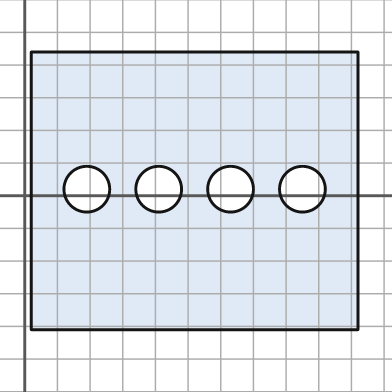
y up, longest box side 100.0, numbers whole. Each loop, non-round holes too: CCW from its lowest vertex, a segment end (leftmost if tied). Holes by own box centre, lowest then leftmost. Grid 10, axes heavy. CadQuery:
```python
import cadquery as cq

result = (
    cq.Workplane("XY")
    .moveTo(2.0, -41.0)
    .lineTo(102.0, -41.0)
    .lineTo(102.0, 44.0)
    .lineTo(2.0, 44.0)
    .close()
    .moveTo(19.0, 2.0)
    .circle(7.0)
    .moveTo(41.0, 2.0)
    .circle(7.0)
    .moveTo(63.0, 2.0)
    .circle(7.0)
    .moveTo(85.0, 2.0)
    .circle(7.0)
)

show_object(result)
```